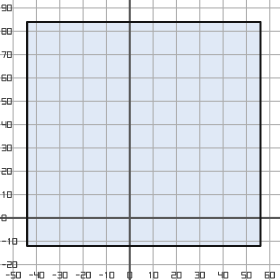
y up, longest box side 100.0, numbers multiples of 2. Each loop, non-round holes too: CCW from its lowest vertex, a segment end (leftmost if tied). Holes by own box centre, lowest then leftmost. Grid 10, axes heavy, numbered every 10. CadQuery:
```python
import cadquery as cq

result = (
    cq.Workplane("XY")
    .moveTo(-44.0, -12.0)
    .lineTo(56.0, -12.0)
    .lineTo(56.0, 84.0)
    .lineTo(-44.0, 84.0)
    .close()
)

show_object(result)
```